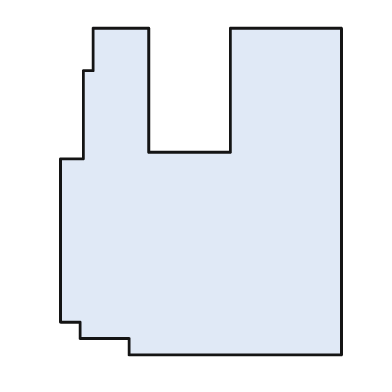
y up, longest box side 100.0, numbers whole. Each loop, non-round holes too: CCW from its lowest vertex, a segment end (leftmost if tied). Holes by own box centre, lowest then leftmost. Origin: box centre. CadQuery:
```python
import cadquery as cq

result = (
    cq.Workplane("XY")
    .moveTo(-22.0, -50.0)
    .lineTo(43.0, -50.0)
    .lineTo(43.0, 50.0)
    .lineTo(9.0, 50.0)
    .lineTo(9.0, 12.0)
    .lineTo(-16.0, 12.0)
    .lineTo(-16.0, 50.0)
    .lineTo(-33.0, 50.0)
    .lineTo(-33.0, 37.0)
    .lineTo(-36.0, 37.0)
    .lineTo(-36.0, 10.0)
    .lineTo(-43.0, 10.0)
    .lineTo(-43.0, -40.0)
    .lineTo(-37.0, -40.0)
    .lineTo(-37.0, -45.0)
    .lineTo(-22.0, -45.0)
    .close()
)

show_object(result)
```